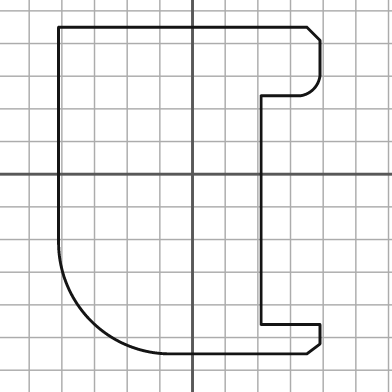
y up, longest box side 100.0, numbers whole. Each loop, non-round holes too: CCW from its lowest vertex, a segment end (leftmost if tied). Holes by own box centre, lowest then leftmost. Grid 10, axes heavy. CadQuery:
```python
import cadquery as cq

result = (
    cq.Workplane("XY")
    .moveTo(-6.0, -55.0)
    .lineTo(35.0, -55.0)
    .lineTo(39.0, -52.0)
    .lineTo(39.0, -46.0)
    .lineTo(21.0, -46.0)
    .lineTo(21.0, 24.0)
    .lineTo(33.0, 24.0)
    .threePointArc((37.0, 26.0), (39.0, 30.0))
    .lineTo(39.0, 41.0)
    .lineTo(35.0, 45.0)
    .lineTo(-41.0, 45.0)
    .lineTo(-41.0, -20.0)
    .threePointArc((-31.0, -45.0), (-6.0, -55.0))
    .close()
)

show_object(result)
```